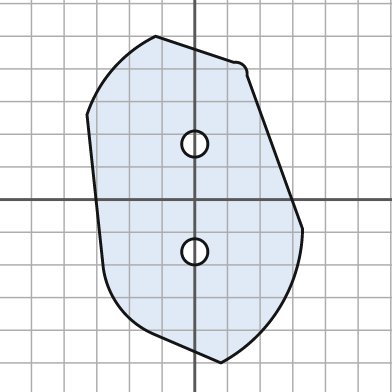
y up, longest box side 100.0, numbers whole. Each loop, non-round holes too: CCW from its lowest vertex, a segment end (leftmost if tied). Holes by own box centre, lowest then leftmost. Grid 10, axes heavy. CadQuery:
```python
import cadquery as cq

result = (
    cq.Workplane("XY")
    .moveTo(8.0, -50.0)
    .threePointArc((26.0, -33.0), (33.0, -9.0))
    .lineTo(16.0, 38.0)
    .threePointArc((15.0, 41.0), (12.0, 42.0))
    .lineTo(-12.0, 50.0)
    .threePointArc((-25.0, 40.0), (-33.0, 26.0))
    .lineTo(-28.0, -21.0)
    .threePointArc((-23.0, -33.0), (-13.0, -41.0))
    .close()
    .moveTo(0.0, -16.0)
    .circle(4.0)
    .moveTo(0.0, 17.0)
    .circle(4.0)
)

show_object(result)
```